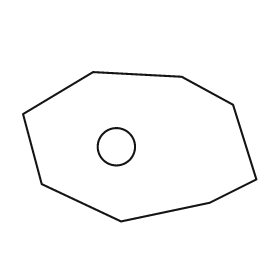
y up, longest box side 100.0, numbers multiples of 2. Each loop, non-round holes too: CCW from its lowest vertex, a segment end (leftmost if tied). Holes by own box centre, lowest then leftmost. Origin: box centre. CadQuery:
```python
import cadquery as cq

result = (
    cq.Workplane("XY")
    .moveTo(-8.0, -32.0)
    .lineTo(30.0, -24.0)
    .lineTo(50.0, -14.0)
    .lineTo(40.0, 18.0)
    .lineTo(18.0, 30.0)
    .lineTo(-20.0, 32.0)
    .lineTo(-50.0, 14.0)
    .lineTo(-42.0, -16.0)
    .close()
    .moveTo(-10.0, 0.0)
    .circle(8.0)
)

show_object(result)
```